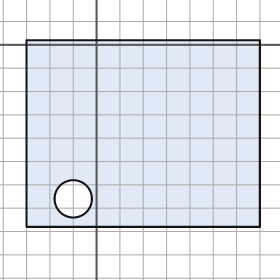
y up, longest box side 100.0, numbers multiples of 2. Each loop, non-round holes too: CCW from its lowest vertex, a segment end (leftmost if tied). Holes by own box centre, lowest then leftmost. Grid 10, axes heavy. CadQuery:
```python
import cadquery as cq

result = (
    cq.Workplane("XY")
    .moveTo(-30.0, -78.0)
    .lineTo(70.0, -78.0)
    .lineTo(70.0, 2.0)
    .lineTo(-30.0, 2.0)
    .close()
    .moveTo(-10.0, -66.0)
    .circle(8.0)
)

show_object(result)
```